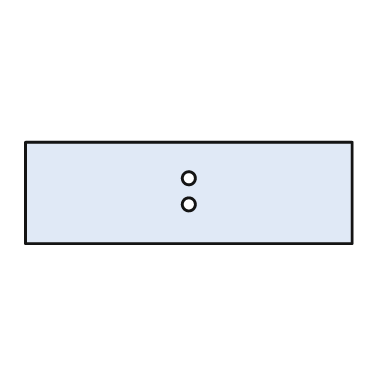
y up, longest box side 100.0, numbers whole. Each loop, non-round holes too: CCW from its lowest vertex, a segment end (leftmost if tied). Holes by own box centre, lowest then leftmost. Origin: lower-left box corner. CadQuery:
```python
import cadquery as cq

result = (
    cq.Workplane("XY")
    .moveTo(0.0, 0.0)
    .lineTo(100.0, 0.0)
    .lineTo(100.0, 31.0)
    .lineTo(0.0, 31.0)
    .close()
    .moveTo(50.0, 12.0)
    .circle(2.0)
    .moveTo(50.0, 20.0)
    .circle(2.0)
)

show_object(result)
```